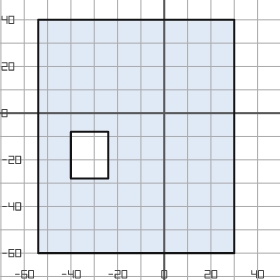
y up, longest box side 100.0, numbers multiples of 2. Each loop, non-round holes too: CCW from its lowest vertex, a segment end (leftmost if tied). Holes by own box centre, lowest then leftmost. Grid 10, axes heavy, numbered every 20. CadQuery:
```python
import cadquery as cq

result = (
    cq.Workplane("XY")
    .moveTo(-54.0, -60.0)
    .lineTo(30.0, -60.0)
    .lineTo(30.0, 40.0)
    .lineTo(-54.0, 40.0)
    .close()
    .moveTo(-40.0, -28.0)
    .lineTo(-24.0, -28.0)
    .lineTo(-24.0, -8.0)
    .lineTo(-40.0, -8.0)
    .close()
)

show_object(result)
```